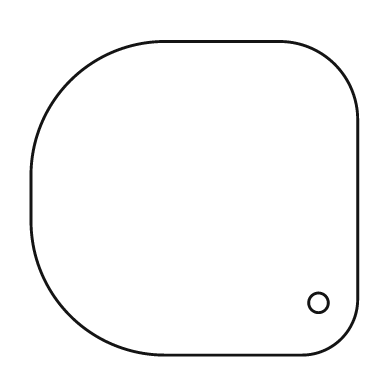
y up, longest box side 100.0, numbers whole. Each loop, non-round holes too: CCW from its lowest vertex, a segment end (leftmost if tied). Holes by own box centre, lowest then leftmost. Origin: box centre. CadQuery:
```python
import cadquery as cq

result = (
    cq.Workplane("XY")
    .moveTo(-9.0, -48.0)
    .lineTo(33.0, -48.0)
    .threePointArc((45.0, -43.0), (50.0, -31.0))
    .lineTo(50.0, 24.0)
    .threePointArc((43.0, 41.0), (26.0, 48.0))
    .lineTo(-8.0, 48.0)
    .threePointArc((-38.0, 36.0), (-50.0, 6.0))
    .lineTo(-50.0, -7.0)
    .threePointArc((-38.0, -36.0), (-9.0, -48.0))
    .close()
    .moveTo(38.0, -32.0)
    .circle(3.0)
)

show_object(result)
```